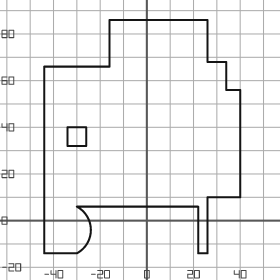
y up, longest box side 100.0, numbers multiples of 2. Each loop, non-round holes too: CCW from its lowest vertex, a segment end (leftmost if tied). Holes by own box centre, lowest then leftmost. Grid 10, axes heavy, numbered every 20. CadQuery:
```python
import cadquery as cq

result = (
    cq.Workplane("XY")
    .moveTo(-44.0, -14.0)
    .lineTo(-30.0, -14.0)
    .threePointArc((-24.0, -4.0), (-30.0, 6.0))
    .lineTo(22.0, 6.0)
    .lineTo(22.0, -14.0)
    .lineTo(26.0, -14.0)
    .lineTo(26.0, 10.0)
    .lineTo(40.0, 10.0)
    .lineTo(40.0, 56.0)
    .lineTo(34.0, 56.0)
    .lineTo(34.0, 68.0)
    .lineTo(26.0, 68.0)
    .lineTo(26.0, 86.0)
    .lineTo(-16.0, 86.0)
    .lineTo(-16.0, 66.0)
    .lineTo(-44.0, 66.0)
    .close()
    .moveTo(-34.0, 32.0)
    .lineTo(-26.0, 32.0)
    .lineTo(-26.0, 40.0)
    .lineTo(-34.0, 40.0)
    .close()
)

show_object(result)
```